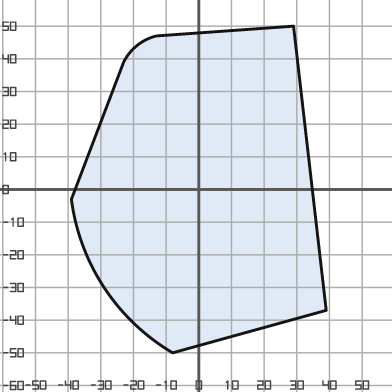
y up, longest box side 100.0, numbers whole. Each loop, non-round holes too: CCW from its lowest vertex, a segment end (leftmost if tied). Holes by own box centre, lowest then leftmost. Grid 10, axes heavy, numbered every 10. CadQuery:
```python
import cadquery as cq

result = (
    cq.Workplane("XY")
    .moveTo(-8.0, -50.0)
    .lineTo(39.0, -37.0)
    .lineTo(29.0, 50.0)
    .lineTo(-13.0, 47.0)
    .threePointArc((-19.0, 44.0), (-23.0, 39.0))
    .lineTo(-39.0, -3.0)
    .threePointArc((-29.0, -30.0), (-8.0, -50.0))
    .close()
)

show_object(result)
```